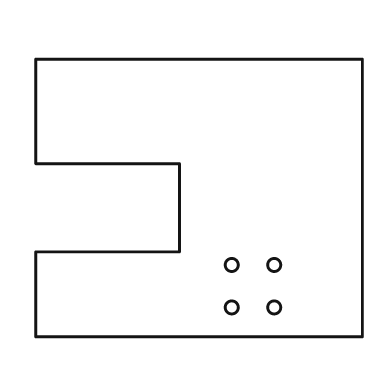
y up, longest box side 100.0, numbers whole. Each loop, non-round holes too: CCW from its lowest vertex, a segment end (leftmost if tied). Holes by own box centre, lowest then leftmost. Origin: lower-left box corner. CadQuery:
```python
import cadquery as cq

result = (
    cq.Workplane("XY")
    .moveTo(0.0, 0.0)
    .lineTo(100.0, 0.0)
    .lineTo(100.0, 85.0)
    .lineTo(0.0, 85.0)
    .lineTo(0.0, 53.0)
    .lineTo(44.0, 53.0)
    .lineTo(44.0, 26.0)
    .lineTo(0.0, 26.0)
    .close()
    .moveTo(60.0, 9.0)
    .circle(2.0)
    .moveTo(73.0, 9.0)
    .circle(2.0)
    .moveTo(60.0, 22.0)
    .circle(2.0)
    .moveTo(73.0, 22.0)
    .circle(2.0)
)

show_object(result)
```